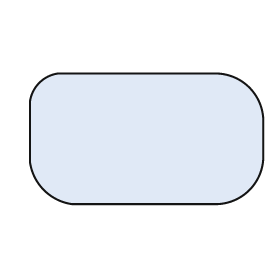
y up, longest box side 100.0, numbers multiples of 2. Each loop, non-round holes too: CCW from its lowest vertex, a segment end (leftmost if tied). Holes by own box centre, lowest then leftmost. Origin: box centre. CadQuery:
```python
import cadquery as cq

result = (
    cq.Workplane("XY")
    .moveTo(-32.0, -28.0)
    .lineTo(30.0, -28.0)
    .threePointArc((44.0, -22.0), (50.0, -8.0))
    .lineTo(50.0, 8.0)
    .threePointArc((44.0, 22.0), (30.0, 28.0))
    .lineTo(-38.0, 28.0)
    .threePointArc((-46.0, 24.0), (-50.0, 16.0))
    .lineTo(-50.0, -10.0)
    .threePointArc((-44.0, -22.0), (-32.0, -28.0))
    .close()
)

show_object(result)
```